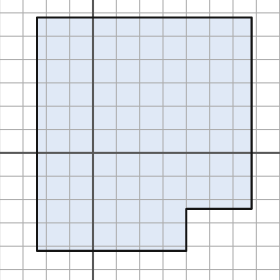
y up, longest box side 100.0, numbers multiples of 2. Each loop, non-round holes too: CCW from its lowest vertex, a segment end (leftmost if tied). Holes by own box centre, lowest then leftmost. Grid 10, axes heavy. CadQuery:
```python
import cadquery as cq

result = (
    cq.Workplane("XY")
    .moveTo(-24.0, -42.0)
    .lineTo(40.0, -42.0)
    .lineTo(40.0, -24.0)
    .lineTo(68.0, -24.0)
    .lineTo(68.0, 58.0)
    .lineTo(-24.0, 58.0)
    .close()
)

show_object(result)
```